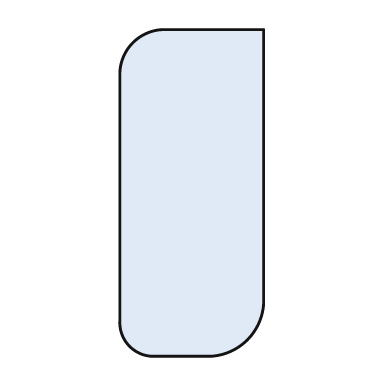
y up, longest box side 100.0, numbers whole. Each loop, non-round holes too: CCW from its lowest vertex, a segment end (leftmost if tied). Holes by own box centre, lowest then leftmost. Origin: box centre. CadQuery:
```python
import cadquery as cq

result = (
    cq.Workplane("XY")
    .moveTo(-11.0, -50.0)
    .lineTo(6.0, -50.0)
    .threePointArc((17.0, -45.0), (22.0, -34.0))
    .lineTo(22.0, 50.0)
    .lineTo(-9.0, 50.0)
    .threePointArc((-18.0, 46.0), (-22.0, 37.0))
    .lineTo(-22.0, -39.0)
    .threePointArc((-19.0, -47.0), (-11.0, -50.0))
    .close()
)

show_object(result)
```